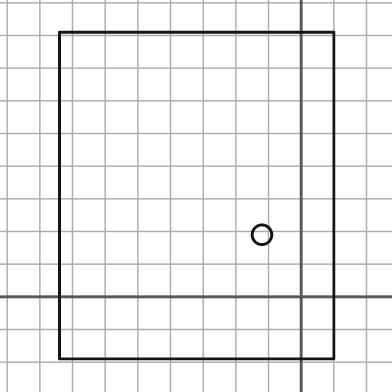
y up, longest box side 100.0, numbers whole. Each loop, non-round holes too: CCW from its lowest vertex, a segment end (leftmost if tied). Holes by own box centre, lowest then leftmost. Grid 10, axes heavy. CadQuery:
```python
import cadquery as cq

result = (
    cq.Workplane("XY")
    .moveTo(-74.0, -19.0)
    .lineTo(10.0, -19.0)
    .lineTo(10.0, 81.0)
    .lineTo(-74.0, 81.0)
    .close()
    .moveTo(-12.0, 19.0)
    .circle(3.0)
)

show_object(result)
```